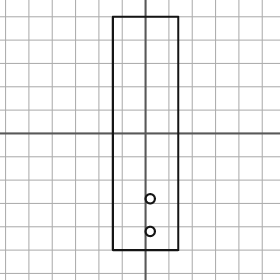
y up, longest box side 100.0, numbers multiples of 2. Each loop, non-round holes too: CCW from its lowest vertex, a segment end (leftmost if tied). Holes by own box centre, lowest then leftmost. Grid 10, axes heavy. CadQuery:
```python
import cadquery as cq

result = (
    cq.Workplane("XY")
    .moveTo(-14.0, -50.0)
    .lineTo(14.0, -50.0)
    .lineTo(14.0, 50.0)
    .lineTo(-14.0, 50.0)
    .close()
    .moveTo(2.0, -42.0)
    .circle(2.0)
    .moveTo(2.0, -28.0)
    .circle(2.0)
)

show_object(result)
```